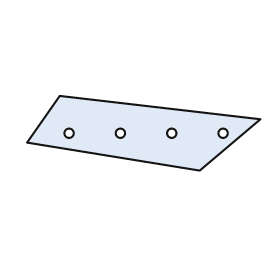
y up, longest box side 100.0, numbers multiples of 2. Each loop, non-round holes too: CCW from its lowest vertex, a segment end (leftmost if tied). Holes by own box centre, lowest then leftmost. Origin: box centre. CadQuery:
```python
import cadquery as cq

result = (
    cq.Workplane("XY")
    .moveTo(24.0, -16.0)
    .lineTo(50.0, 6.0)
    .lineTo(-36.0, 16.0)
    .lineTo(-50.0, -4.0)
    .close()
    .moveTo(-32.0, 0.0)
    .circle(2.0)
    .moveTo(-10.0, 0.0)
    .circle(2.0)
    .moveTo(12.0, 0.0)
    .circle(2.0)
    .moveTo(34.0, 0.0)
    .circle(2.0)
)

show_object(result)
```